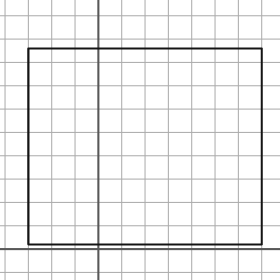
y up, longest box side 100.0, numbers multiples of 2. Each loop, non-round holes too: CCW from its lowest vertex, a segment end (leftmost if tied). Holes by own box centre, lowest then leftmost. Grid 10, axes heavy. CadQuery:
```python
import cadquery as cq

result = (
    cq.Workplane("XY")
    .moveTo(-30.0, 2.0)
    .lineTo(70.0, 2.0)
    .lineTo(70.0, 86.0)
    .lineTo(-30.0, 86.0)
    .close()
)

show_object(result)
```